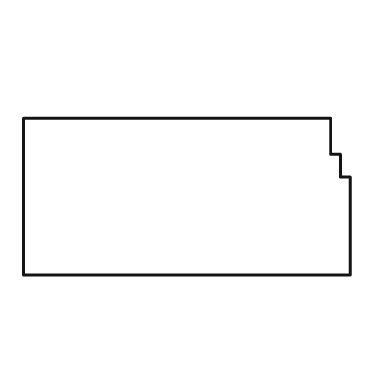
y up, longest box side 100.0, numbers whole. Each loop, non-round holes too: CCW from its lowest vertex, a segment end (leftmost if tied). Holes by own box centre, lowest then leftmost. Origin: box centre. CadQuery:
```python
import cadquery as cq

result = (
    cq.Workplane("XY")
    .moveTo(-50.0, -24.0)
    .lineTo(50.0, -24.0)
    .lineTo(50.0, 6.0)
    .lineTo(47.0, 6.0)
    .lineTo(47.0, 13.0)
    .lineTo(44.0, 13.0)
    .lineTo(44.0, 24.0)
    .lineTo(-50.0, 24.0)
    .close()
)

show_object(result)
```